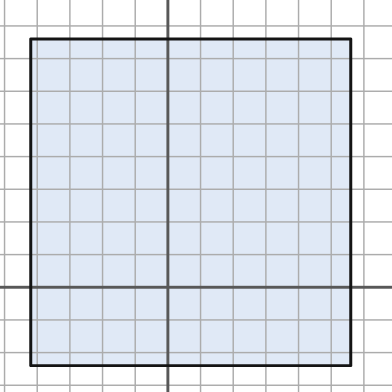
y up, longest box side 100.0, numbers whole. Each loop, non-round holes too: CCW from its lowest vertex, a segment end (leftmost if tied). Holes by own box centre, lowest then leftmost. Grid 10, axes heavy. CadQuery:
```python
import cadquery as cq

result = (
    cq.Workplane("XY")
    .moveTo(-42.0, -24.0)
    .lineTo(56.0, -24.0)
    .lineTo(56.0, 76.0)
    .lineTo(-42.0, 76.0)
    .close()
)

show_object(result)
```